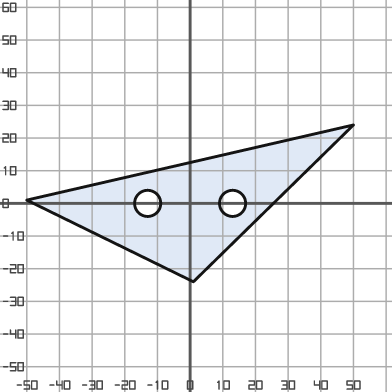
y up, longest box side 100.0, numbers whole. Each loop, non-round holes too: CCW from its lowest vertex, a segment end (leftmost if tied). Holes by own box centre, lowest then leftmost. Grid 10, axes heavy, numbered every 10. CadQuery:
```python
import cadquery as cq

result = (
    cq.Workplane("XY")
    .moveTo(1.0, -24.0)
    .lineTo(50.0, 24.0)
    .lineTo(-50.0, 1.0)
    .close()
    .moveTo(-13.0, 0.0)
    .circle(4.0)
    .moveTo(13.0, 0.0)
    .circle(4.0)
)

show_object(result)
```